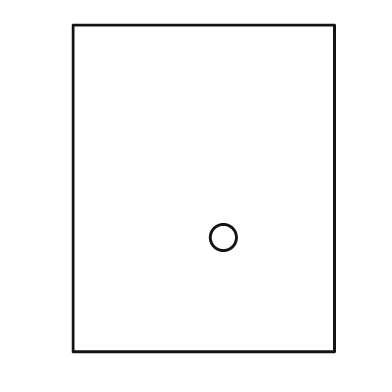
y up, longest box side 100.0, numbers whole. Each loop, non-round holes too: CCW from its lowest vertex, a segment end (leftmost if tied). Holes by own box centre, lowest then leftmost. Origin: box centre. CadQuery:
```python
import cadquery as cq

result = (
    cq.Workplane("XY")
    .moveTo(-40.0, -50.0)
    .lineTo(40.0, -50.0)
    .lineTo(40.0, 50.0)
    .lineTo(-40.0, 50.0)
    .close()
    .moveTo(6.0, -15.0)
    .circle(4.0)
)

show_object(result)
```